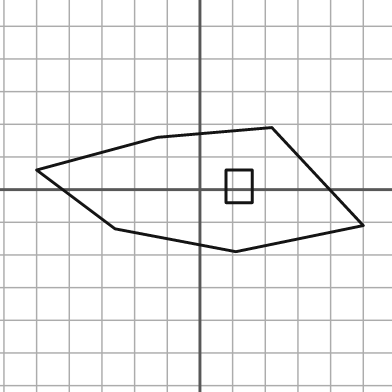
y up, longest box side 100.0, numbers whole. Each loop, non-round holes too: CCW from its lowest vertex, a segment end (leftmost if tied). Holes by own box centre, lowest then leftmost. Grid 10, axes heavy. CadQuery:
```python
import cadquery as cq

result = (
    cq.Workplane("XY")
    .moveTo(11.0, -19.0)
    .lineTo(50.0, -11.0)
    .lineTo(22.0, 19.0)
    .lineTo(-13.0, 16.0)
    .lineTo(-50.0, 6.0)
    .lineTo(-26.0, -12.0)
    .close()
    .moveTo(8.0, -4.0)
    .lineTo(16.0, -4.0)
    .lineTo(16.0, 6.0)
    .lineTo(8.0, 6.0)
    .close()
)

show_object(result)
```